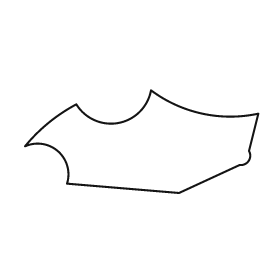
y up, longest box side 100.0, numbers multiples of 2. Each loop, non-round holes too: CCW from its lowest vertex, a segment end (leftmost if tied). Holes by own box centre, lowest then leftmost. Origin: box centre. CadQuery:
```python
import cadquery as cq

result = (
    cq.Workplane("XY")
    .moveTo(16.0, -22.0)
    .lineTo(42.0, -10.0)
    .threePointArc((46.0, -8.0), (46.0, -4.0))
    .lineTo(50.0, 12.0)
    .threePointArc((26.0, 12.0), (4.0, 22.0))
    .threePointArc((-10.0, 8.0), (-28.0, 16.0))
    .threePointArc((-40.0, 8.0), (-50.0, -2.0))
    .threePointArc((-36.0, -4.0), (-32.0, -18.0))
    .close()
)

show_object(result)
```